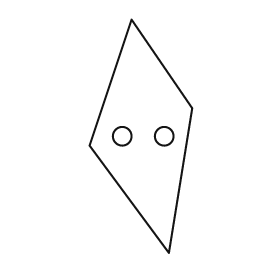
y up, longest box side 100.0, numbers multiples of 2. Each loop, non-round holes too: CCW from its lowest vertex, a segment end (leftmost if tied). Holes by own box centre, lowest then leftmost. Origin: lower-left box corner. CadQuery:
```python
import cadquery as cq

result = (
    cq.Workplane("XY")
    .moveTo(34.0, 0.0)
    .lineTo(44.0, 62.0)
    .lineTo(18.0, 100.0)
    .lineTo(0.0, 46.0)
    .close()
    .moveTo(14.0, 50.0)
    .circle(4.0)
    .moveTo(32.0, 50.0)
    .circle(4.0)
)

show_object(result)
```